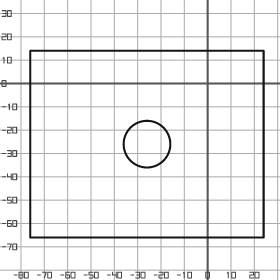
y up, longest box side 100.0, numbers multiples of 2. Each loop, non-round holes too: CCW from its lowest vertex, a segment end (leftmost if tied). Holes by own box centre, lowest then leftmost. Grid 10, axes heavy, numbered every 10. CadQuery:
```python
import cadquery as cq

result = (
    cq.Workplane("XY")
    .moveTo(-76.0, -66.0)
    .lineTo(24.0, -66.0)
    .lineTo(24.0, 14.0)
    .lineTo(-76.0, 14.0)
    .close()
    .moveTo(-26.0, -26.0)
    .circle(10.0)
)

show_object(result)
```